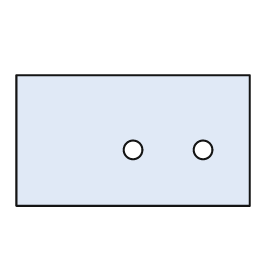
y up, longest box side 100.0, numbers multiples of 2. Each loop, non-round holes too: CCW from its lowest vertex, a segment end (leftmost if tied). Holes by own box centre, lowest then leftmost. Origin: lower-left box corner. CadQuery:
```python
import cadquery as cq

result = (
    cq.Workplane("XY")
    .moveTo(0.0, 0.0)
    .lineTo(100.0, 0.0)
    .lineTo(100.0, 56.0)
    .lineTo(0.0, 56.0)
    .close()
    .moveTo(50.0, 24.0)
    .circle(4.0)
    .moveTo(80.0, 24.0)
    .circle(4.0)
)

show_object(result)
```